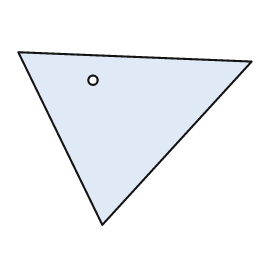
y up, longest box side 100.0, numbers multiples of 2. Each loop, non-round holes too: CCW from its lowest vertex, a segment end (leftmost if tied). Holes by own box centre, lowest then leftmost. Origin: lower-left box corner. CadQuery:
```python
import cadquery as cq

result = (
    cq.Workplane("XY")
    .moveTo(36.0, 0.0)
    .lineTo(100.0, 70.0)
    .lineTo(0.0, 74.0)
    .close()
    .moveTo(32.0, 62.0)
    .circle(2.0)
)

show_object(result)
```